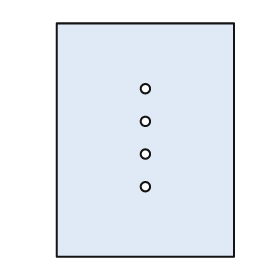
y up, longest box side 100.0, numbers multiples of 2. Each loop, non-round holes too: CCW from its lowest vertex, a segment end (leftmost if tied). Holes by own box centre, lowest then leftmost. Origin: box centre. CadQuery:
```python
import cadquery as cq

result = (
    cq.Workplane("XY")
    .moveTo(-38.0, -50.0)
    .lineTo(38.0, -50.0)
    .lineTo(38.0, 50.0)
    .lineTo(-38.0, 50.0)
    .close()
    .moveTo(0.0, -20.0)
    .circle(2.0)
    .moveTo(0.0, -6.0)
    .circle(2.0)
    .moveTo(0.0, 8.0)
    .circle(2.0)
    .moveTo(0.0, 22.0)
    .circle(2.0)
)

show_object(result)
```